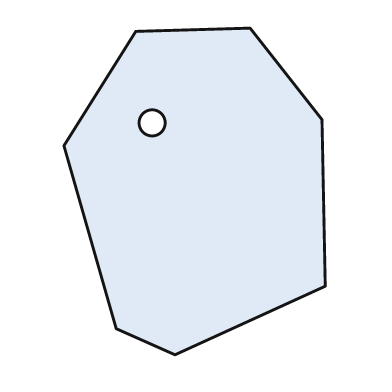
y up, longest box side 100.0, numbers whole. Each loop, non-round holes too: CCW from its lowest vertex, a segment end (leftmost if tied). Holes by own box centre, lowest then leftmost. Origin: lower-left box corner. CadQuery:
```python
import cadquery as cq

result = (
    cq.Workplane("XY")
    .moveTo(34.0, 0.0)
    .lineTo(80.0, 21.0)
    .lineTo(79.0, 72.0)
    .lineTo(57.0, 100.0)
    .lineTo(22.0, 99.0)
    .lineTo(0.0, 64.0)
    .lineTo(16.0, 8.0)
    .close()
    .moveTo(27.0, 71.0)
    .circle(4.0)
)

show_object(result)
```